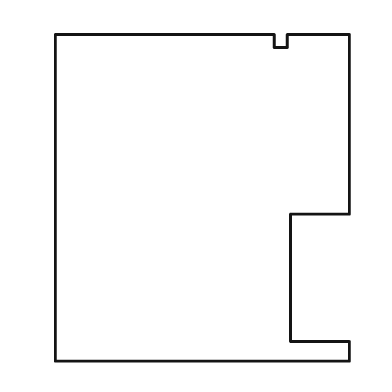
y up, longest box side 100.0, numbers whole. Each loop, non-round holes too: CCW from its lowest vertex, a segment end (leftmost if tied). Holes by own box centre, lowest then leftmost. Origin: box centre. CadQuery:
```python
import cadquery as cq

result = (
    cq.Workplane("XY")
    .moveTo(-45.0, -50.0)
    .lineTo(45.0, -50.0)
    .lineTo(45.0, -44.0)
    .lineTo(27.0, -44.0)
    .lineTo(27.0, -5.0)
    .lineTo(45.0, -5.0)
    .lineTo(45.0, 50.0)
    .lineTo(26.0, 50.0)
    .lineTo(26.0, 46.0)
    .lineTo(22.0, 46.0)
    .lineTo(22.0, 50.0)
    .lineTo(-45.0, 50.0)
    .close()
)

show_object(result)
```